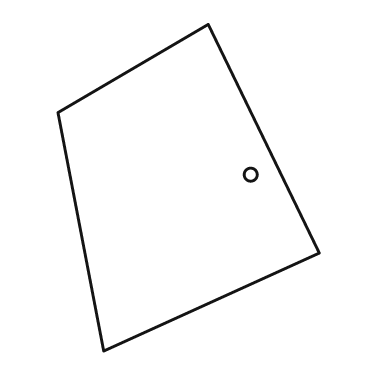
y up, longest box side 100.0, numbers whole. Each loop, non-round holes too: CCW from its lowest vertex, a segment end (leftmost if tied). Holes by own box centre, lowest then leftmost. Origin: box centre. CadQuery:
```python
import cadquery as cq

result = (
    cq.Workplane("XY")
    .moveTo(-26.0, -50.0)
    .lineTo(40.0, -20.0)
    .lineTo(6.0, 50.0)
    .lineTo(-40.0, 23.0)
    .close()
    .moveTo(19.0, 4.0)
    .circle(2.0)
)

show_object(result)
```